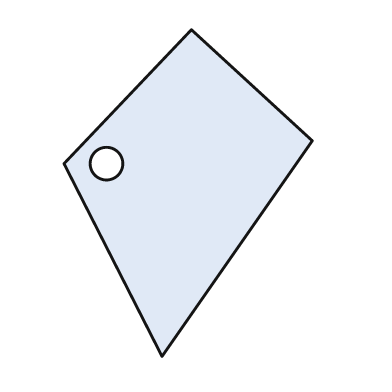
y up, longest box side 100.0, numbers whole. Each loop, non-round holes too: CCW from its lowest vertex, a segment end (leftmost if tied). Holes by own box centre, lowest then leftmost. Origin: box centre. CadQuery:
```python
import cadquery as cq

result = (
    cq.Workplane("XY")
    .moveTo(-8.0, -50.0)
    .lineTo(38.0, 16.0)
    .lineTo(1.0, 50.0)
    .lineTo(-38.0, 9.0)
    .close()
    .moveTo(-25.0, 9.0)
    .circle(5.0)
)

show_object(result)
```